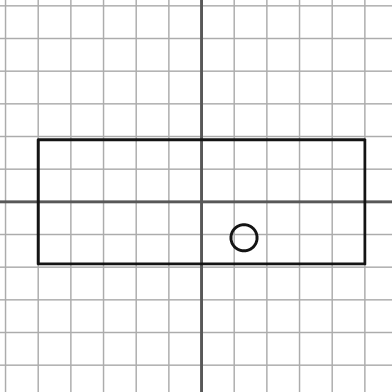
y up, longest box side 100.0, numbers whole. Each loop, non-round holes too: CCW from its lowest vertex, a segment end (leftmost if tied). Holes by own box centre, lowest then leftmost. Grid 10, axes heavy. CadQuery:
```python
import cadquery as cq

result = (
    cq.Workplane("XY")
    .moveTo(-50.0, -19.0)
    .lineTo(50.0, -19.0)
    .lineTo(50.0, 19.0)
    .lineTo(-50.0, 19.0)
    .close()
    .moveTo(13.0, -11.0)
    .circle(4.0)
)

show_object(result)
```